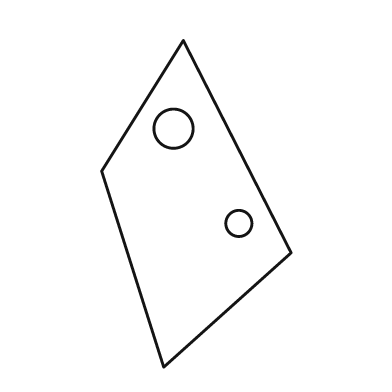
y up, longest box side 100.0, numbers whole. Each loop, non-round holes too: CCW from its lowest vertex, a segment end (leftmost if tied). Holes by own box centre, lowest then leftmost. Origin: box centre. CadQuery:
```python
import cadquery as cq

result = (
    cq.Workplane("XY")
    .moveTo(-10.0, -50.0)
    .lineTo(29.0, -15.0)
    .lineTo(-4.0, 50.0)
    .lineTo(-29.0, 10.0)
    .close()
    .moveTo(13.0, -6.0)
    .circle(4.0)
    .moveTo(-7.0, 23.0)
    .circle(6.0)
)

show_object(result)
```